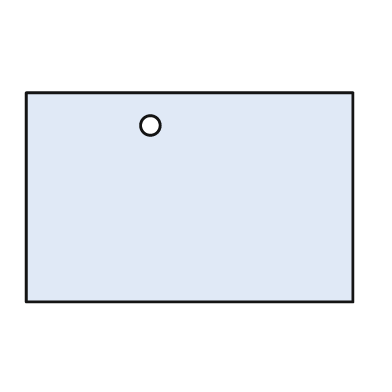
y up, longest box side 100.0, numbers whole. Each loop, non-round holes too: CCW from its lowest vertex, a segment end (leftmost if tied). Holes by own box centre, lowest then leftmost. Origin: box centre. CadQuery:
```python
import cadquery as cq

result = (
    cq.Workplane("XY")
    .moveTo(-50.0, -32.0)
    .lineTo(50.0, -32.0)
    .lineTo(50.0, 32.0)
    .lineTo(-50.0, 32.0)
    .close()
    .moveTo(-12.0, 22.0)
    .circle(3.0)
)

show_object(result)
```